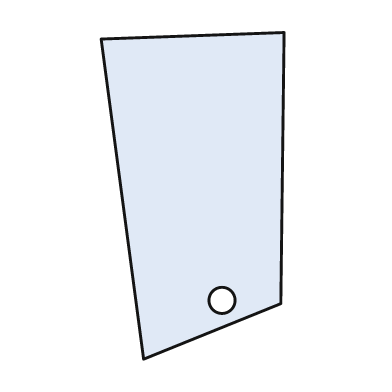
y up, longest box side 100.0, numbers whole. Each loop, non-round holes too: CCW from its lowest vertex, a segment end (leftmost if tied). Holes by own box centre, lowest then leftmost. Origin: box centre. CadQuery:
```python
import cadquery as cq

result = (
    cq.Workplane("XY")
    .moveTo(-15.0, -50.0)
    .lineTo(27.0, -33.0)
    .lineTo(28.0, 50.0)
    .lineTo(-28.0, 48.0)
    .close()
    .moveTo(9.0, -32.0)
    .circle(4.0)
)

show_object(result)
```